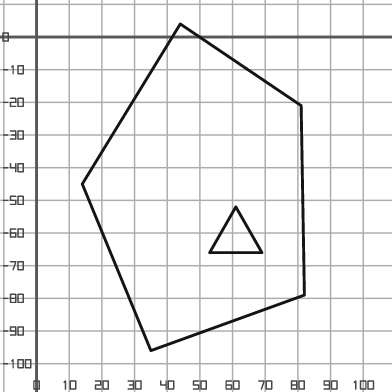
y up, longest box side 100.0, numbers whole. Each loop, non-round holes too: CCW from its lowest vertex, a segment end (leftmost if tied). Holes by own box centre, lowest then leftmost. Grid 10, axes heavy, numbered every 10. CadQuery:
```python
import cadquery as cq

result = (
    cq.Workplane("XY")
    .moveTo(35.0, -96.0)
    .lineTo(82.0, -79.0)
    .lineTo(81.0, -21.0)
    .lineTo(44.0, 4.0)
    .lineTo(14.0, -45.0)
    .close()
    .moveTo(53.0, -66.0)
    .lineTo(69.0, -66.0)
    .lineTo(61.0, -52.0)
    .close()
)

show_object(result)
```